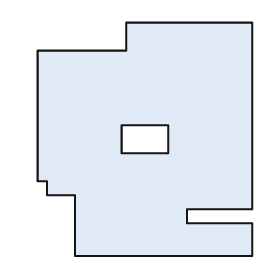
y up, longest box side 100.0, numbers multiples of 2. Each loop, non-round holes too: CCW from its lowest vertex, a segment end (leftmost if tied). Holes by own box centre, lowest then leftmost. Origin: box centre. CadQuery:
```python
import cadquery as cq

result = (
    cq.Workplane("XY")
    .moveTo(-30.0, -50.0)
    .lineTo(46.0, -50.0)
    .lineTo(46.0, -36.0)
    .lineTo(18.0, -36.0)
    .lineTo(18.0, -30.0)
    .lineTo(46.0, -30.0)
    .lineTo(46.0, 50.0)
    .lineTo(-8.0, 50.0)
    .lineTo(-8.0, 38.0)
    .lineTo(-46.0, 38.0)
    .lineTo(-46.0, -18.0)
    .lineTo(-42.0, -18.0)
    .lineTo(-42.0, -24.0)
    .lineTo(-30.0, -24.0)
    .close()
    .moveTo(-10.0, -6.0)
    .lineTo(10.0, -6.0)
    .lineTo(10.0, 6.0)
    .lineTo(-10.0, 6.0)
    .close()
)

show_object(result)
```